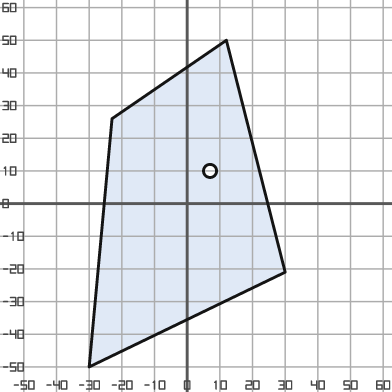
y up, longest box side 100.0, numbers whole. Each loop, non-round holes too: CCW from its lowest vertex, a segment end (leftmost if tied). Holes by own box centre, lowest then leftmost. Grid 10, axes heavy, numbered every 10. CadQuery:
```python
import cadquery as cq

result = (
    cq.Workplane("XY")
    .moveTo(-30.0, -50.0)
    .lineTo(30.0, -21.0)
    .lineTo(12.0, 50.0)
    .lineTo(-23.0, 26.0)
    .close()
    .moveTo(7.0, 10.0)
    .circle(2.0)
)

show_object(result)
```